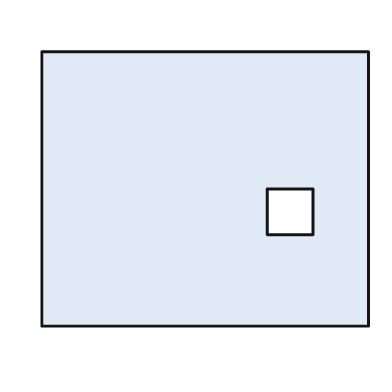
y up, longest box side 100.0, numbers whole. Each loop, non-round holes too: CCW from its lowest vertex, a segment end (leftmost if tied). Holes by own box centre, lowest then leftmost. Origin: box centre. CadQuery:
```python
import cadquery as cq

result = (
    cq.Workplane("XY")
    .moveTo(-50.0, -42.0)
    .lineTo(50.0, -42.0)
    .lineTo(50.0, 42.0)
    .lineTo(-50.0, 42.0)
    .close()
    .moveTo(19.0, -14.0)
    .lineTo(33.0, -14.0)
    .lineTo(33.0, 0.0)
    .lineTo(19.0, 0.0)
    .close()
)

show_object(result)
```